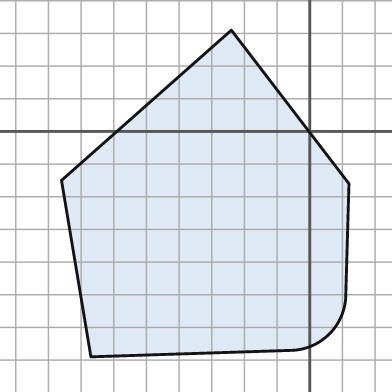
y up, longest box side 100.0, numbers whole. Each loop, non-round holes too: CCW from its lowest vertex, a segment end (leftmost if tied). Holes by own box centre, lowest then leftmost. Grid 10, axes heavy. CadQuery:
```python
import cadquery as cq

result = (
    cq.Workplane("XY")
    .moveTo(-67.0, -69.0)
    .lineTo(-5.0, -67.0)
    .threePointArc((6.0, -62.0), (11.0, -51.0))
    .lineTo(12.0, -16.0)
    .lineTo(-24.0, 31.0)
    .lineTo(-76.0, -15.0)
    .close()
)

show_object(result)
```